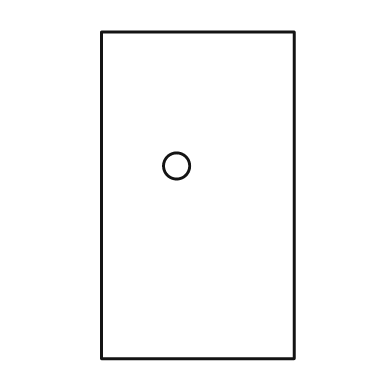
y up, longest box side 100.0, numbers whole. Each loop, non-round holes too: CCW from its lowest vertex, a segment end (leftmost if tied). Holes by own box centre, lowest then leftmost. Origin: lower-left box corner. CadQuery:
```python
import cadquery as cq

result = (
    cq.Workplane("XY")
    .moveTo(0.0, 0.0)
    .lineTo(59.0, 0.0)
    .lineTo(59.0, 100.0)
    .lineTo(0.0, 100.0)
    .close()
    .moveTo(23.0, 59.0)
    .circle(4.0)
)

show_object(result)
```